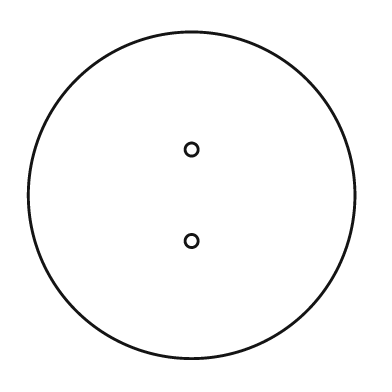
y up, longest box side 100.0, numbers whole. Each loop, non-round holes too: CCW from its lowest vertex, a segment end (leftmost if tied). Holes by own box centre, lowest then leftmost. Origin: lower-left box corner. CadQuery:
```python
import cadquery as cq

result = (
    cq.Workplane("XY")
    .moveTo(50.0, 50.0)
    .circle(50.0)
    .moveTo(50.0, 36.0)
    .circle(2.0)
    .moveTo(50.0, 64.0)
    .circle(2.0)
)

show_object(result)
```